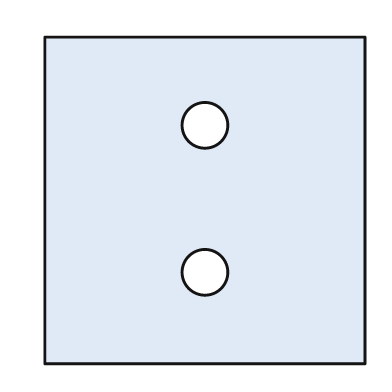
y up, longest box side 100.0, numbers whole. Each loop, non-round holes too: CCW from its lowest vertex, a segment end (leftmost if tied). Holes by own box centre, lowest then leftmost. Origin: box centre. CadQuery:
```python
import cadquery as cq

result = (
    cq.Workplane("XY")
    .moveTo(-49.0, -50.0)
    .lineTo(49.0, -50.0)
    .lineTo(49.0, 50.0)
    .lineTo(-49.0, 50.0)
    .close()
    .moveTo(0.0, -22.0)
    .circle(7.0)
    .moveTo(0.0, 23.0)
    .circle(7.0)
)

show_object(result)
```